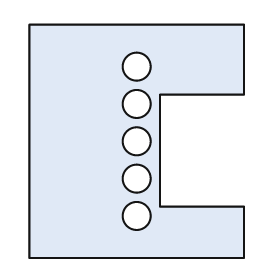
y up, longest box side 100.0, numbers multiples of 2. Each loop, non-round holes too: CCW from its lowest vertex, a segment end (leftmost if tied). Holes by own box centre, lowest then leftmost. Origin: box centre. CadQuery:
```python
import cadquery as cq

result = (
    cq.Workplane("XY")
    .moveTo(-46.0, -50.0)
    .lineTo(46.0, -50.0)
    .lineTo(46.0, -28.0)
    .lineTo(10.0, -28.0)
    .lineTo(10.0, 20.0)
    .lineTo(46.0, 20.0)
    .lineTo(46.0, 50.0)
    .lineTo(-46.0, 50.0)
    .close()
    .moveTo(0.0, -32.0)
    .circle(6.0)
    .moveTo(0.0, -16.0)
    .circle(6.0)
    .moveTo(0.0, 0.0)
    .circle(6.0)
    .moveTo(0.0, 16.0)
    .circle(6.0)
    .moveTo(0.0, 32.0)
    .circle(6.0)
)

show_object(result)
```